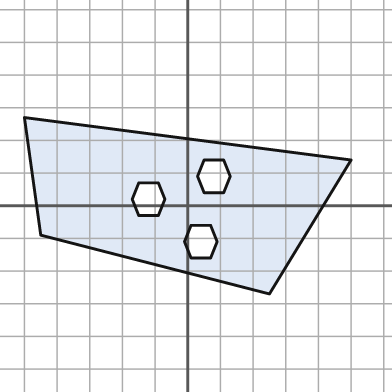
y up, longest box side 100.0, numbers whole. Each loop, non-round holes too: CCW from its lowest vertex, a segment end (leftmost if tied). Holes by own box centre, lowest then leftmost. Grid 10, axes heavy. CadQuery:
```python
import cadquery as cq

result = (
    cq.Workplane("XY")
    .moveTo(25.0, -27.0)
    .lineTo(50.0, 14.0)
    .lineTo(-50.0, 27.0)
    .lineTo(-45.0, -9.0)
    .close()
    .moveTo(1.0, -16.0)
    .lineTo(7.0, -16.0)
    .lineTo(9.0, -11.0)
    .lineTo(7.0, -6.0)
    .lineTo(1.0, -6.0)
    .lineTo(-1.0, -11.0)
    .close()
    .moveTo(-15.0, -3.0)
    .lineTo(-9.0, -3.0)
    .lineTo(-7.0, 2.0)
    .lineTo(-9.0, 7.0)
    .lineTo(-15.0, 7.0)
    .lineTo(-17.0, 2.0)
    .close()
    .moveTo(5.0, 4.0)
    .lineTo(11.0, 4.0)
    .lineTo(13.0, 9.0)
    .lineTo(11.0, 14.0)
    .lineTo(5.0, 14.0)
    .lineTo(3.0, 9.0)
    .close()
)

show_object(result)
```